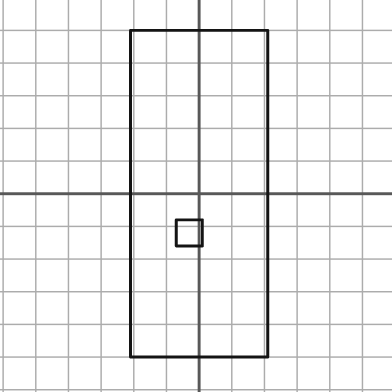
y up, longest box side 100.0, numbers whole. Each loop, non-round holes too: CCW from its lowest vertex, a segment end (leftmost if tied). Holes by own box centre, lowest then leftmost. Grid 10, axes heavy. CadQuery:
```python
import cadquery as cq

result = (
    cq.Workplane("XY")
    .moveTo(-21.0, -50.0)
    .lineTo(21.0, -50.0)
    .lineTo(21.0, 50.0)
    .lineTo(-21.0, 50.0)
    .close()
    .moveTo(-7.0, -16.0)
    .lineTo(1.0, -16.0)
    .lineTo(1.0, -8.0)
    .lineTo(-7.0, -8.0)
    .close()
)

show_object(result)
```